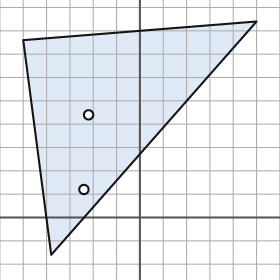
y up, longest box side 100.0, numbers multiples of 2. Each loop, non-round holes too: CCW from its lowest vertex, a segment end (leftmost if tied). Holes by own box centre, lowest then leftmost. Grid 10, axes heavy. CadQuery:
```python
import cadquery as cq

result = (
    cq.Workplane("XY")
    .moveTo(-38.0, -16.0)
    .lineTo(50.0, 84.0)
    .lineTo(-50.0, 76.0)
    .close()
    .moveTo(-24.0, 12.0)
    .circle(2.0)
    .moveTo(-22.0, 44.0)
    .circle(2.0)
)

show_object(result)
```